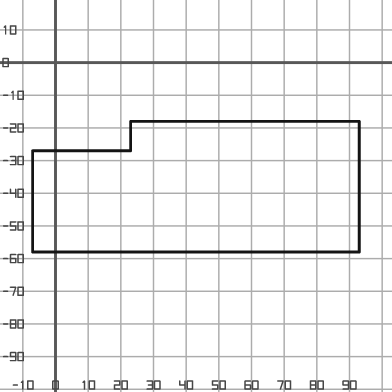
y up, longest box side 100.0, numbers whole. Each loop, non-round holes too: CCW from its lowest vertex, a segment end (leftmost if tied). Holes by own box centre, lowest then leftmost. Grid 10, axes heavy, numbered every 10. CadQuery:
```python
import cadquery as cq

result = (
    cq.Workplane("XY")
    .moveTo(-7.0, -58.0)
    .lineTo(93.0, -58.0)
    .lineTo(93.0, -18.0)
    .lineTo(23.0, -18.0)
    .lineTo(23.0, -27.0)
    .lineTo(-7.0, -27.0)
    .close()
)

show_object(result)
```